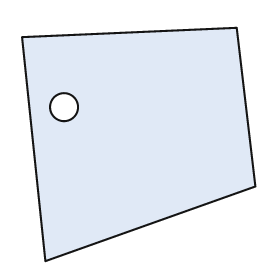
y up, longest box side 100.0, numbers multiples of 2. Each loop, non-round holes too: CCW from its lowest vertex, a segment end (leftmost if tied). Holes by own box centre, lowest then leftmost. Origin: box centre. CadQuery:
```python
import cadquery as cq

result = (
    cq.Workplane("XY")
    .moveTo(-40.0, -50.0)
    .lineTo(50.0, -18.0)
    .lineTo(42.0, 50.0)
    .lineTo(-50.0, 46.0)
    .close()
    .moveTo(-32.0, 16.0)
    .circle(6.0)
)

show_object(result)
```